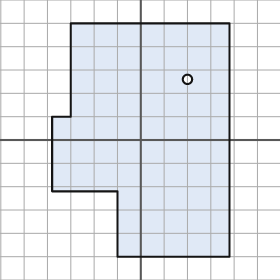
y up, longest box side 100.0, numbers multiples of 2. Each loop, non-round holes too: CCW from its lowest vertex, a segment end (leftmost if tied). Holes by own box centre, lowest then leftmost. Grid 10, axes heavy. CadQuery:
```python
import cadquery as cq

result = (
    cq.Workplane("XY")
    .moveTo(-10.0, -50.0)
    .lineTo(38.0, -50.0)
    .lineTo(38.0, 50.0)
    .lineTo(-30.0, 50.0)
    .lineTo(-30.0, 10.0)
    .lineTo(-38.0, 10.0)
    .lineTo(-38.0, -22.0)
    .lineTo(-10.0, -22.0)
    .close()
    .moveTo(20.0, 26.0)
    .circle(2.0)
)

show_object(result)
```